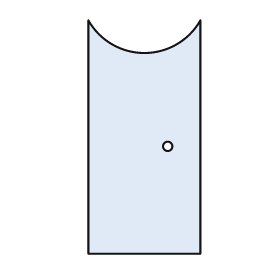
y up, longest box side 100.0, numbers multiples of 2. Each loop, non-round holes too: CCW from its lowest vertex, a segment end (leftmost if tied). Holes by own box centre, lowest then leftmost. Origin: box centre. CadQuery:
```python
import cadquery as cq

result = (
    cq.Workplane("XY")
    .moveTo(-24.0, -50.0)
    .lineTo(24.0, -50.0)
    .lineTo(24.0, 50.0)
    .threePointArc((0.0, 36.0), (-24.0, 50.0))
    .close()
    .moveTo(10.0, -4.0)
    .circle(2.0)
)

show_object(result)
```